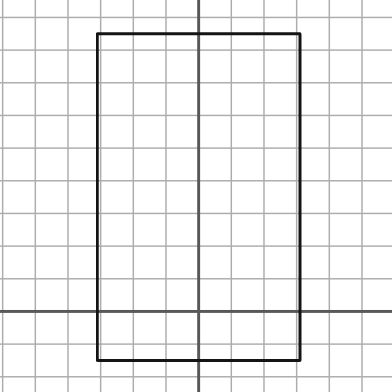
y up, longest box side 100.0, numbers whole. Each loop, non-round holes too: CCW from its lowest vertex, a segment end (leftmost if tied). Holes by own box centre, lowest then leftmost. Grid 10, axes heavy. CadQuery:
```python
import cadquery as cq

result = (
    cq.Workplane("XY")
    .moveTo(-31.0, -15.0)
    .lineTo(31.0, -15.0)
    .lineTo(31.0, 85.0)
    .lineTo(-31.0, 85.0)
    .close()
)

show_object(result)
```